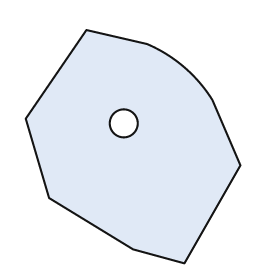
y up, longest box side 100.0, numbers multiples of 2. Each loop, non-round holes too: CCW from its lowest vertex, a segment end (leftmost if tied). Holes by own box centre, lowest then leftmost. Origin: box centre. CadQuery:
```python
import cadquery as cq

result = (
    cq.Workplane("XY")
    .moveTo(22.0, -50.0)
    .lineTo(46.0, -8.0)
    .lineTo(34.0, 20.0)
    .threePointArc((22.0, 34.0), (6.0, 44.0))
    .lineTo(-20.0, 50.0)
    .lineTo(-46.0, 12.0)
    .lineTo(-36.0, -22.0)
    .lineTo(0.0, -44.0)
    .close()
    .moveTo(-4.0, 10.0)
    .circle(6.0)
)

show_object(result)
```